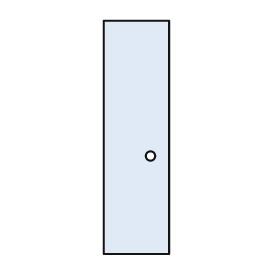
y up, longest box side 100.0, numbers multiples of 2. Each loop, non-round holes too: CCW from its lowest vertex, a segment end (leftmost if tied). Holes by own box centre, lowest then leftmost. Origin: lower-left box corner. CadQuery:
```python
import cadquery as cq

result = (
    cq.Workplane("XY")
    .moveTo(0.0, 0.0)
    .lineTo(28.0, 0.0)
    .lineTo(28.0, 100.0)
    .lineTo(0.0, 100.0)
    .close()
    .moveTo(20.0, 42.0)
    .circle(2.0)
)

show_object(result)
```